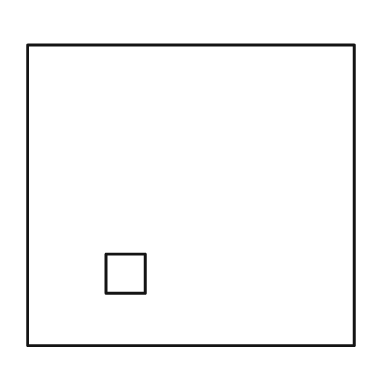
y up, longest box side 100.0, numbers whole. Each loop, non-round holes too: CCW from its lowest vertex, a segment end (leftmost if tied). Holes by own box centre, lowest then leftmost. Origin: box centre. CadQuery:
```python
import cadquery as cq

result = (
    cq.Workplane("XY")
    .moveTo(-50.0, -46.0)
    .lineTo(50.0, -46.0)
    .lineTo(50.0, 46.0)
    .lineTo(-50.0, 46.0)
    .close()
    .moveTo(-26.0, -30.0)
    .lineTo(-14.0, -30.0)
    .lineTo(-14.0, -18.0)
    .lineTo(-26.0, -18.0)
    .close()
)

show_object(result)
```